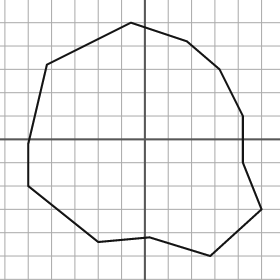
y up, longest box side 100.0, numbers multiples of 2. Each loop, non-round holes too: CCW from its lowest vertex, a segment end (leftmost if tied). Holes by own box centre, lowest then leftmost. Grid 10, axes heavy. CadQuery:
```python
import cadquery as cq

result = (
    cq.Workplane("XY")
    .moveTo(28.0, -50.0)
    .lineTo(50.0, -30.0)
    .lineTo(42.0, -10.0)
    .lineTo(42.0, 10.0)
    .lineTo(32.0, 30.0)
    .lineTo(18.0, 42.0)
    .lineTo(-6.0, 50.0)
    .lineTo(-42.0, 32.0)
    .lineTo(-50.0, -2.0)
    .lineTo(-50.0, -20.0)
    .lineTo(-20.0, -44.0)
    .lineTo(2.0, -42.0)
    .close()
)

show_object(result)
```